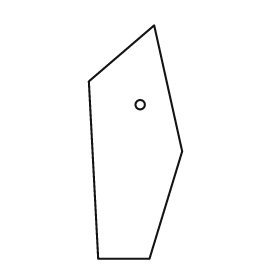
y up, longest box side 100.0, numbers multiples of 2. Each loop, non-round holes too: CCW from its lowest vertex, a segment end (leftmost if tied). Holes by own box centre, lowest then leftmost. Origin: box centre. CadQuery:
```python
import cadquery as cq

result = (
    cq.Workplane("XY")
    .moveTo(-16.0, -50.0)
    .lineTo(6.0, -50.0)
    .lineTo(20.0, -4.0)
    .lineTo(8.0, 50.0)
    .lineTo(-20.0, 26.0)
    .close()
    .moveTo(2.0, 16.0)
    .circle(2.0)
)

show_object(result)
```